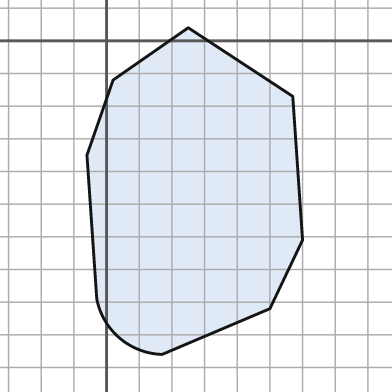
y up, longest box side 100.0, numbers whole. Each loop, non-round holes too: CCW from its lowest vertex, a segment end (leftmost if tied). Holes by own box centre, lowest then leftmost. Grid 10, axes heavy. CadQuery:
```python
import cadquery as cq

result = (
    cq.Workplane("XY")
    .moveTo(17.0, -96.0)
    .lineTo(50.0, -82.0)
    .lineTo(60.0, -61.0)
    .lineTo(57.0, -17.0)
    .lineTo(25.0, 4.0)
    .lineTo(2.0, -12.0)
    .lineTo(-6.0, -35.0)
    .lineTo(-3.0, -79.0)
    .threePointArc((4.0, -91.0), (17.0, -96.0))
    .close()
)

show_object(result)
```